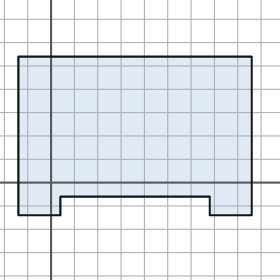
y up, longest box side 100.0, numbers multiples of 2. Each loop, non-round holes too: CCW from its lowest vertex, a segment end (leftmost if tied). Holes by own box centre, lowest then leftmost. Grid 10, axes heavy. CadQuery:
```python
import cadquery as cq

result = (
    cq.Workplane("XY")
    .moveTo(-14.0, -14.0)
    .lineTo(4.0, -14.0)
    .lineTo(4.0, -6.0)
    .lineTo(68.0, -6.0)
    .lineTo(68.0, -14.0)
    .lineTo(86.0, -14.0)
    .lineTo(86.0, 54.0)
    .lineTo(-14.0, 54.0)
    .close()
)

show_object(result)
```